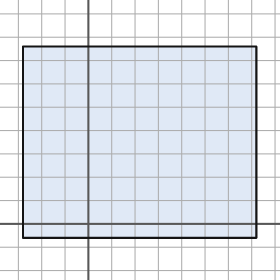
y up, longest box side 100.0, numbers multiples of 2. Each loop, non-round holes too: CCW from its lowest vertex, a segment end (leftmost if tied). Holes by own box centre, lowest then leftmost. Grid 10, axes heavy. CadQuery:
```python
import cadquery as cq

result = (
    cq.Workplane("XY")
    .moveTo(-28.0, -6.0)
    .lineTo(72.0, -6.0)
    .lineTo(72.0, 76.0)
    .lineTo(-28.0, 76.0)
    .close()
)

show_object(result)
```